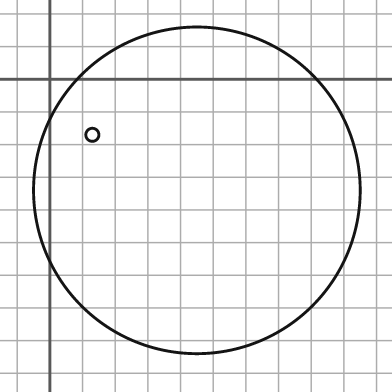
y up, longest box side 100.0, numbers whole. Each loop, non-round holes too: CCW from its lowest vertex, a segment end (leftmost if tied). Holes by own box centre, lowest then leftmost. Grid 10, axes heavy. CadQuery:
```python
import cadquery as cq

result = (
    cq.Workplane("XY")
    .moveTo(45.0, -34.0)
    .circle(50.0)
    .moveTo(13.0, -17.0)
    .circle(2.0)
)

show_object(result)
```